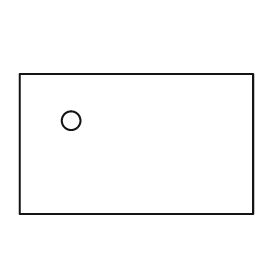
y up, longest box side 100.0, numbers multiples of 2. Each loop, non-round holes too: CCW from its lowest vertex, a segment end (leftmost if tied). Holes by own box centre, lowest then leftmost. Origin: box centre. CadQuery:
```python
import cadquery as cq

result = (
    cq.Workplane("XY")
    .moveTo(-50.0, -30.0)
    .lineTo(50.0, -30.0)
    .lineTo(50.0, 30.0)
    .lineTo(-50.0, 30.0)
    .close()
    .moveTo(-28.0, 10.0)
    .circle(4.0)
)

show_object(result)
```